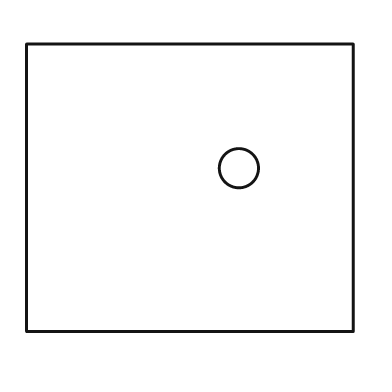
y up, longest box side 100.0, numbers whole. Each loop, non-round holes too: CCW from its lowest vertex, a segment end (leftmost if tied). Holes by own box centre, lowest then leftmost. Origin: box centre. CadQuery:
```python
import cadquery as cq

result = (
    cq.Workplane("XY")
    .moveTo(-50.0, -44.0)
    .lineTo(50.0, -44.0)
    .lineTo(50.0, 44.0)
    .lineTo(-50.0, 44.0)
    .close()
    .moveTo(15.0, 6.0)
    .circle(6.0)
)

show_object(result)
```